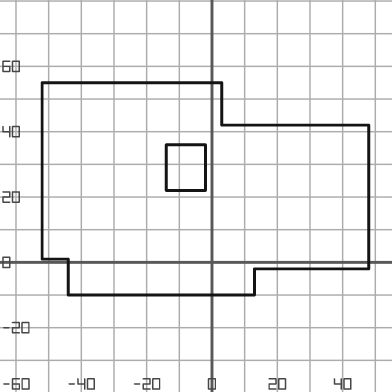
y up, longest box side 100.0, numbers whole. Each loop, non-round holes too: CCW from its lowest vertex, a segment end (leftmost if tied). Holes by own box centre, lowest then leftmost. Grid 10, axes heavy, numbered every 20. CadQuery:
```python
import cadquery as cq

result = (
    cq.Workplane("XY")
    .moveTo(-44.0, -10.0)
    .lineTo(13.0, -10.0)
    .lineTo(13.0, -2.0)
    .lineTo(48.0, -2.0)
    .lineTo(48.0, 42.0)
    .lineTo(3.0, 42.0)
    .lineTo(3.0, 55.0)
    .lineTo(-52.0, 55.0)
    .lineTo(-52.0, 1.0)
    .lineTo(-44.0, 1.0)
    .close()
    .moveTo(-14.0, 22.0)
    .lineTo(-2.0, 22.0)
    .lineTo(-2.0, 36.0)
    .lineTo(-14.0, 36.0)
    .close()
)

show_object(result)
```